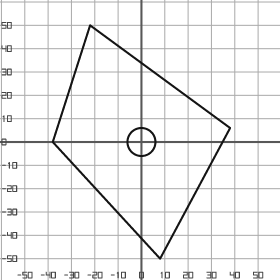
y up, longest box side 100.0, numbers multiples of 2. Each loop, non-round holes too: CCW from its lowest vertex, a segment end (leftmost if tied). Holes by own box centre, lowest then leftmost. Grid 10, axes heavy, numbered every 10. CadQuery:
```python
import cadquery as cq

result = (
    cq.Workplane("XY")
    .moveTo(8.0, -50.0)
    .lineTo(38.0, 6.0)
    .lineTo(-22.0, 50.0)
    .lineTo(-38.0, 0.0)
    .close()
    .moveTo(0.0, 0.0)
    .circle(6.0)
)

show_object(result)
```